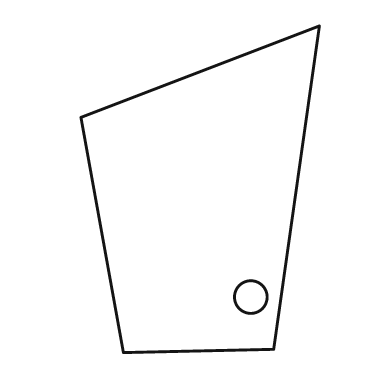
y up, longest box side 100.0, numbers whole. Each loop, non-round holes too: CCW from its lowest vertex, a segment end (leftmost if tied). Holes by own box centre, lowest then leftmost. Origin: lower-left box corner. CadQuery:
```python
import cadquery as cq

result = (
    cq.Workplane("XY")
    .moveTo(13.0, 0.0)
    .lineTo(59.0, 1.0)
    .lineTo(73.0, 100.0)
    .lineTo(0.0, 72.0)
    .close()
    .moveTo(52.0, 17.0)
    .circle(5.0)
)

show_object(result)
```